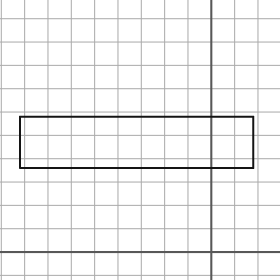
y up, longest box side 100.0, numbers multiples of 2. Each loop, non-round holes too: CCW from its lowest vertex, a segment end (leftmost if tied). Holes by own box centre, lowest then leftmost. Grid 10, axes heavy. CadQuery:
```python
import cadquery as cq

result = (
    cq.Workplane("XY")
    .moveTo(-82.0, 36.0)
    .lineTo(18.0, 36.0)
    .lineTo(18.0, 58.0)
    .lineTo(-82.0, 58.0)
    .close()
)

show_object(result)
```